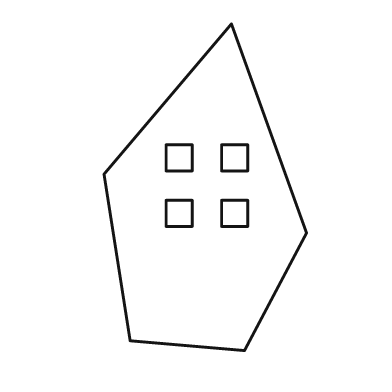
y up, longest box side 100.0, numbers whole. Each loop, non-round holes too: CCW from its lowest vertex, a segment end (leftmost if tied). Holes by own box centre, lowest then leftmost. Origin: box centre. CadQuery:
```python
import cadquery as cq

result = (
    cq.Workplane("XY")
    .moveTo(12.0, -50.0)
    .lineTo(31.0, -14.0)
    .lineTo(8.0, 50.0)
    .lineTo(-31.0, 4.0)
    .lineTo(-23.0, -47.0)
    .close()
    .moveTo(-12.0, -12.0)
    .lineTo(-4.0, -12.0)
    .lineTo(-4.0, -4.0)
    .lineTo(-12.0, -4.0)
    .close()
    .moveTo(5.0, -12.0)
    .lineTo(13.0, -12.0)
    .lineTo(13.0, -4.0)
    .lineTo(5.0, -4.0)
    .close()
    .moveTo(-12.0, 5.0)
    .lineTo(-4.0, 5.0)
    .lineTo(-4.0, 13.0)
    .lineTo(-12.0, 13.0)
    .close()
    .moveTo(5.0, 5.0)
    .lineTo(13.0, 5.0)
    .lineTo(13.0, 13.0)
    .lineTo(5.0, 13.0)
    .close()
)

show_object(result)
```